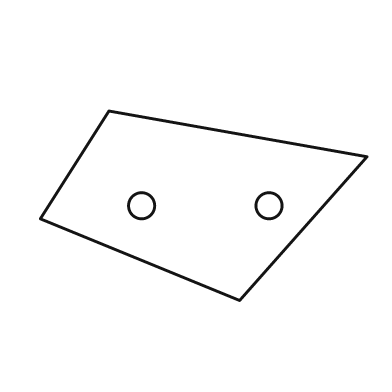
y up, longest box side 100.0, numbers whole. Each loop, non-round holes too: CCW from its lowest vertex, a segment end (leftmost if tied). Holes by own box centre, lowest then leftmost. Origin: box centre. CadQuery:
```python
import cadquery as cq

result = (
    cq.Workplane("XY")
    .moveTo(11.0, -29.0)
    .lineTo(50.0, 15.0)
    .lineTo(-29.0, 29.0)
    .lineTo(-50.0, -4.0)
    .close()
    .moveTo(-19.0, 0.0)
    .circle(4.0)
    .moveTo(20.0, 0.0)
    .circle(4.0)
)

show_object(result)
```